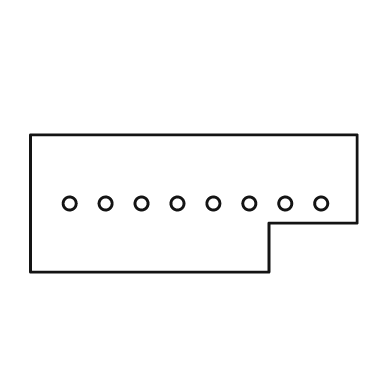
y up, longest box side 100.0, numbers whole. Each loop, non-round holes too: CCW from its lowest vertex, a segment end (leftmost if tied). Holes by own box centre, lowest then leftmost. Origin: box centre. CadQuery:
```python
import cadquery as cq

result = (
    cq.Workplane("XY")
    .moveTo(-50.0, -21.0)
    .lineTo(23.0, -21.0)
    .lineTo(23.0, -6.0)
    .lineTo(50.0, -6.0)
    .lineTo(50.0, 21.0)
    .lineTo(-50.0, 21.0)
    .close()
    .moveTo(-38.0, 0.0)
    .circle(2.0)
    .moveTo(-27.0, 0.0)
    .circle(2.0)
    .moveTo(-16.0, 0.0)
    .circle(2.0)
    .moveTo(-5.0, 0.0)
    .circle(2.0)
    .moveTo(6.0, 0.0)
    .circle(2.0)
    .moveTo(17.0, 0.0)
    .circle(2.0)
    .moveTo(28.0, 0.0)
    .circle(2.0)
    .moveTo(39.0, 0.0)
    .circle(2.0)
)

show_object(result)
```